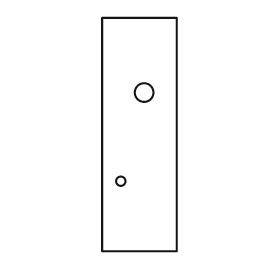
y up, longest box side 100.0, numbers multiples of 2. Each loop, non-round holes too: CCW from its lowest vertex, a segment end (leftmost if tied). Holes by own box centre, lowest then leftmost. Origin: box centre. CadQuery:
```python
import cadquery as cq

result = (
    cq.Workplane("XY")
    .moveTo(-16.0, -50.0)
    .lineTo(16.0, -50.0)
    .lineTo(16.0, 50.0)
    .lineTo(-16.0, 50.0)
    .close()
    .moveTo(-8.0, -20.0)
    .circle(2.0)
    .moveTo(2.0, 18.0)
    .circle(4.0)
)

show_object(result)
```